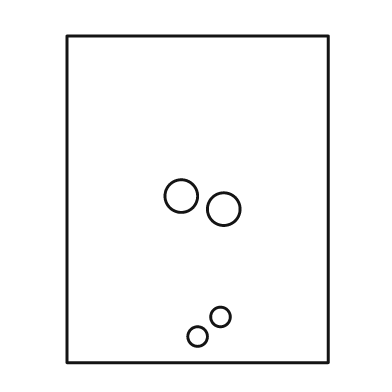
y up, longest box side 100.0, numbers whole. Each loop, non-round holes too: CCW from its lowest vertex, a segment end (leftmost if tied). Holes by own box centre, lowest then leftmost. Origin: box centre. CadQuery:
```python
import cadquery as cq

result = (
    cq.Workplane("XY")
    .moveTo(-40.0, -50.0)
    .lineTo(40.0, -50.0)
    .lineTo(40.0, 50.0)
    .lineTo(-40.0, 50.0)
    .close()
    .moveTo(0.0, -42.0)
    .circle(3.0)
    .moveTo(7.0, -36.0)
    .circle(3.0)
    .moveTo(8.0, -3.0)
    .circle(5.0)
    .moveTo(-5.0, 1.0)
    .circle(5.0)
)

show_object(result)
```